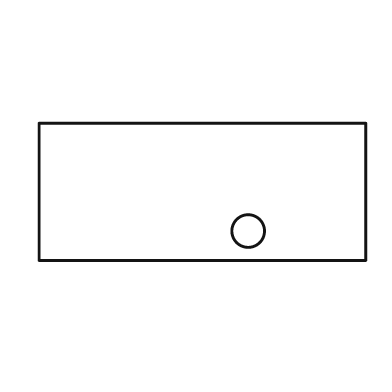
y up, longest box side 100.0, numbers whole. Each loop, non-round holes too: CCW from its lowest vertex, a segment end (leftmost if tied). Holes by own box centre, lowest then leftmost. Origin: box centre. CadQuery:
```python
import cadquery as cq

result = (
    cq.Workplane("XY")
    .moveTo(-50.0, -21.0)
    .lineTo(50.0, -21.0)
    .lineTo(50.0, 21.0)
    .lineTo(-50.0, 21.0)
    .close()
    .moveTo(14.0, -12.0)
    .circle(5.0)
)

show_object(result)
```